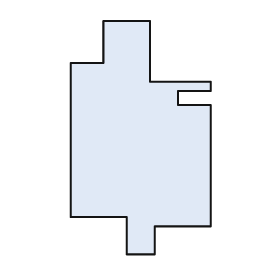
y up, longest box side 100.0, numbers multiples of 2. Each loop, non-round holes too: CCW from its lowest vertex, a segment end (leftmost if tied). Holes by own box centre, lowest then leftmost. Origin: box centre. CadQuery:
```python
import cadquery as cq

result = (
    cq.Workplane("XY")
    .moveTo(-6.0, -50.0)
    .lineTo(6.0, -50.0)
    .lineTo(6.0, -38.0)
    .lineTo(30.0, -38.0)
    .lineTo(30.0, 14.0)
    .lineTo(16.0, 14.0)
    .lineTo(16.0, 20.0)
    .lineTo(30.0, 20.0)
    .lineTo(30.0, 24.0)
    .lineTo(4.0, 24.0)
    .lineTo(4.0, 50.0)
    .lineTo(-16.0, 50.0)
    .lineTo(-16.0, 32.0)
    .lineTo(-30.0, 32.0)
    .lineTo(-30.0, -34.0)
    .lineTo(-6.0, -34.0)
    .close()
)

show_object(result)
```